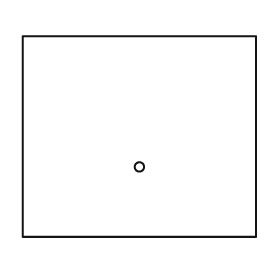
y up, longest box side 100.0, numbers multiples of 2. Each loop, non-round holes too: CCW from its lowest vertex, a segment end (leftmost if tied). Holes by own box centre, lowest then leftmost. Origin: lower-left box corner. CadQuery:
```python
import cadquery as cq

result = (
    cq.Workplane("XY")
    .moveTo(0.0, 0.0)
    .lineTo(100.0, 0.0)
    .lineTo(100.0, 86.0)
    .lineTo(0.0, 86.0)
    .close()
    .moveTo(50.0, 30.0)
    .circle(2.0)
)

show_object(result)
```